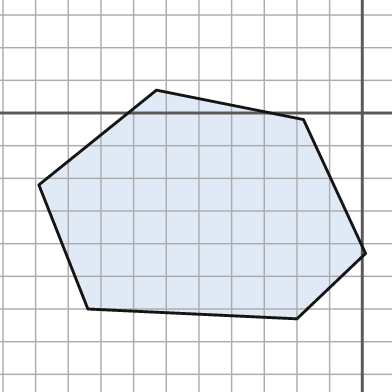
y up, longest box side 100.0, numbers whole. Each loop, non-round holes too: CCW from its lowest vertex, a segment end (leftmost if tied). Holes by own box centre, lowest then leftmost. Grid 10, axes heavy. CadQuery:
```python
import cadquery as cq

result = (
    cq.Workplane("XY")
    .moveTo(-20.0, -63.0)
    .lineTo(1.0, -43.0)
    .lineTo(-18.0, -2.0)
    .lineTo(-63.0, 7.0)
    .lineTo(-99.0, -22.0)
    .lineTo(-84.0, -60.0)
    .close()
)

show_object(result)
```